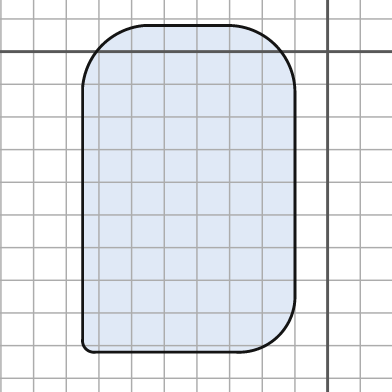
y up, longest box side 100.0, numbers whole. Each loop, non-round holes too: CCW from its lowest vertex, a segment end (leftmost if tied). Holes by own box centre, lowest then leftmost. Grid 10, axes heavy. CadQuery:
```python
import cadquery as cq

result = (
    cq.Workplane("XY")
    .moveTo(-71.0, -92.0)
    .lineTo(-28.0, -92.0)
    .threePointArc((-15.0, -87.0), (-10.0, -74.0))
    .lineTo(-10.0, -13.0)
    .threePointArc((-16.0, 2.0), (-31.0, 8.0))
    .lineTo(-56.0, 8.0)
    .threePointArc((-69.0, 2.0), (-75.0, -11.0))
    .lineTo(-75.0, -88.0)
    .threePointArc((-74.0, -91.0), (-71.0, -92.0))
    .close()
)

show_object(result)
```